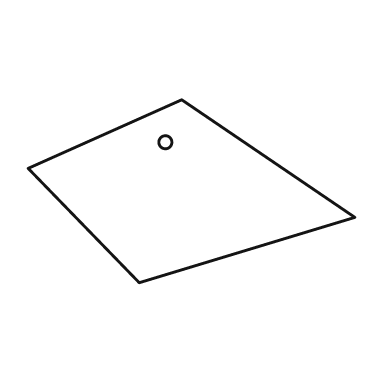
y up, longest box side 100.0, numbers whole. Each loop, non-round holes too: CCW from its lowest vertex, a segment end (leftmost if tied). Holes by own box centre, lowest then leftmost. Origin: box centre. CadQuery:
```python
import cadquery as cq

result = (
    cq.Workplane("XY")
    .moveTo(-16.0, -28.0)
    .lineTo(50.0, -8.0)
    .lineTo(-3.0, 28.0)
    .lineTo(-50.0, 7.0)
    .close()
    .moveTo(-8.0, 15.0)
    .circle(2.0)
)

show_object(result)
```